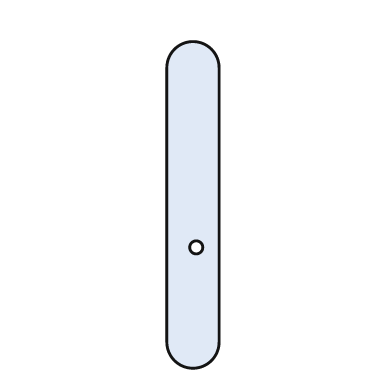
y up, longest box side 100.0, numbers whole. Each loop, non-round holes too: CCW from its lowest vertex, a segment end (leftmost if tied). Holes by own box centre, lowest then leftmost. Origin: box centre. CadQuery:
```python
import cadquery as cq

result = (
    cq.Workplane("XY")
    .moveTo(-8.0, -42.0)
    .threePointArc((0.0, -50.0), (8.0, -42.0))
    .lineTo(8.0, 42.0)
    .threePointArc((0.0, 50.0), (-8.0, 42.0))
    .close()
    .moveTo(1.0, -13.0)
    .circle(2.0)
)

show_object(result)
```